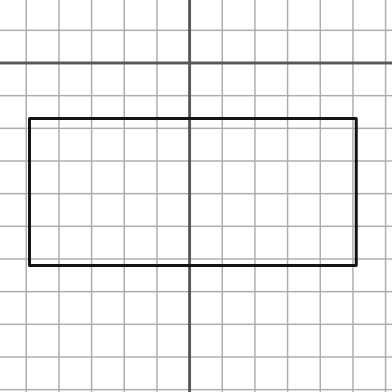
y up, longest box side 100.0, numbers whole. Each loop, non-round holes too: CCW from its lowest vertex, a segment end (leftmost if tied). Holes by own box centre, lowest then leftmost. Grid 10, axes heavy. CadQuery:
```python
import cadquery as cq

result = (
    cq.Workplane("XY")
    .moveTo(-49.0, -62.0)
    .lineTo(51.0, -62.0)
    .lineTo(51.0, -17.0)
    .lineTo(-49.0, -17.0)
    .close()
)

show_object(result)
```